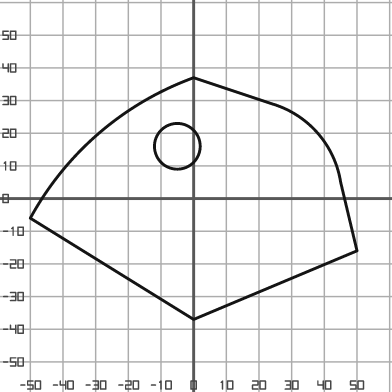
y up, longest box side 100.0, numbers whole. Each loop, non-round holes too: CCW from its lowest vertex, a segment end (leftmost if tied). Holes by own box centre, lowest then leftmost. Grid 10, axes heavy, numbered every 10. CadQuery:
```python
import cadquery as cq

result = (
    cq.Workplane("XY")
    .moveTo(0.0, -37.0)
    .lineTo(50.0, -16.0)
    .lineTo(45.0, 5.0)
    .threePointArc((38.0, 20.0), (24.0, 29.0))
    .lineTo(0.0, 37.0)
    .threePointArc((-29.0, 20.0), (-50.0, -6.0))
    .close()
    .moveTo(-5.0, 16.0)
    .circle(7.0)
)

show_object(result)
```